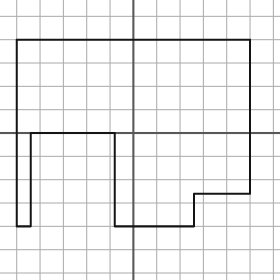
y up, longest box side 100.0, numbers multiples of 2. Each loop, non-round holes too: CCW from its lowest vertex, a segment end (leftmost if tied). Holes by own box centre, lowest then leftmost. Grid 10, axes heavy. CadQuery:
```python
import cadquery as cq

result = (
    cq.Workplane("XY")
    .moveTo(-50.0, -40.0)
    .lineTo(-44.0, -40.0)
    .lineTo(-44.0, 0.0)
    .lineTo(-8.0, 0.0)
    .lineTo(-8.0, -40.0)
    .lineTo(26.0, -40.0)
    .lineTo(26.0, -26.0)
    .lineTo(50.0, -26.0)
    .lineTo(50.0, 40.0)
    .lineTo(-50.0, 40.0)
    .close()
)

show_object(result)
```